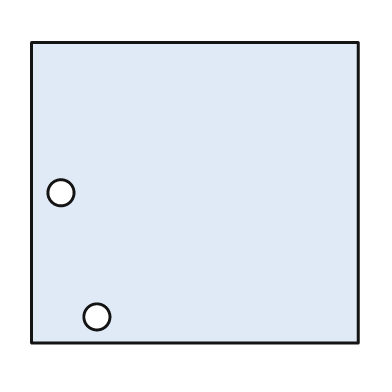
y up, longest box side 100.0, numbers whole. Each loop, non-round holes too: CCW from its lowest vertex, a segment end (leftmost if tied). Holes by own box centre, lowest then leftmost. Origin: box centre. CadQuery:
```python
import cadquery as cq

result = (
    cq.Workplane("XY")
    .moveTo(-50.0, -46.0)
    .lineTo(50.0, -46.0)
    .lineTo(50.0, 46.0)
    .lineTo(-50.0, 46.0)
    .close()
    .moveTo(-30.0, -38.0)
    .circle(4.0)
    .moveTo(-41.0, 0.0)
    .circle(4.0)
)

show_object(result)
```